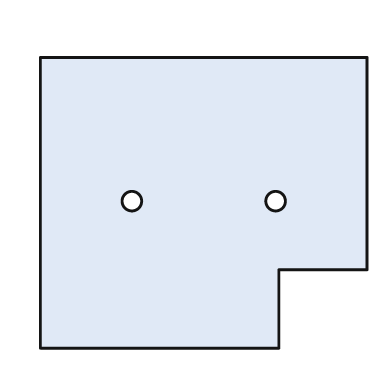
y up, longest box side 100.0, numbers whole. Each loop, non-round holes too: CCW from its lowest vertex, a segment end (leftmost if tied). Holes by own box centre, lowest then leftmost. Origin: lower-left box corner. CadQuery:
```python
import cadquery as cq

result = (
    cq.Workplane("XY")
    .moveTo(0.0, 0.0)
    .lineTo(73.0, 0.0)
    .lineTo(73.0, 24.0)
    .lineTo(100.0, 24.0)
    .lineTo(100.0, 89.0)
    .lineTo(0.0, 89.0)
    .close()
    .moveTo(28.0, 45.0)
    .circle(3.0)
    .moveTo(72.0, 45.0)
    .circle(3.0)
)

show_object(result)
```